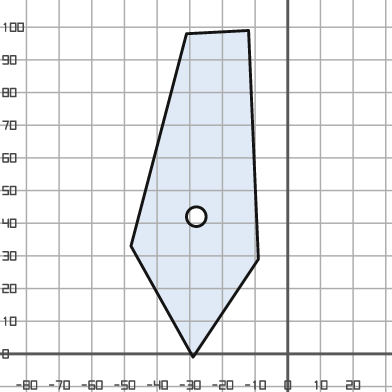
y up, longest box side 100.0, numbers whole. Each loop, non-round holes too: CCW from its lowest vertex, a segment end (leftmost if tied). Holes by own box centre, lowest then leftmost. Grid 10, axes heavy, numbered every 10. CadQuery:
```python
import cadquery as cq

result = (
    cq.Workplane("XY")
    .moveTo(-29.0, -1.0)
    .lineTo(-9.0, 29.0)
    .lineTo(-12.0, 99.0)
    .lineTo(-31.0, 98.0)
    .lineTo(-48.0, 33.0)
    .close()
    .moveTo(-28.0, 42.0)
    .circle(3.0)
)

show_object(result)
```